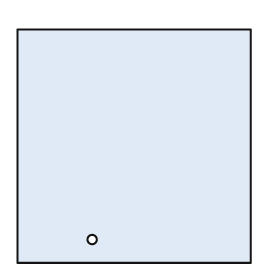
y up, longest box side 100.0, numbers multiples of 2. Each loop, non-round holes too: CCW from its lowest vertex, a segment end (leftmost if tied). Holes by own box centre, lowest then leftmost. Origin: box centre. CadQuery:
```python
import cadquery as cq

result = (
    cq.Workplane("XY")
    .moveTo(-50.0, -50.0)
    .lineTo(50.0, -50.0)
    .lineTo(50.0, 50.0)
    .lineTo(-50.0, 50.0)
    .close()
    .moveTo(-18.0, -40.0)
    .circle(2.0)
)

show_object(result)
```